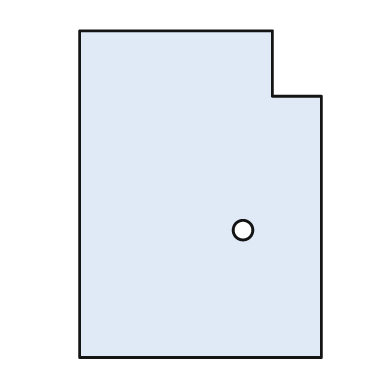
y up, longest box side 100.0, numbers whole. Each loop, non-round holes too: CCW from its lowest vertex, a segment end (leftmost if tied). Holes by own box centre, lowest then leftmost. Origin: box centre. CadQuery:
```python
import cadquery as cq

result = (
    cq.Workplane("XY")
    .moveTo(-37.0, -50.0)
    .lineTo(37.0, -50.0)
    .lineTo(37.0, 30.0)
    .lineTo(22.0, 30.0)
    .lineTo(22.0, 50.0)
    .lineTo(-37.0, 50.0)
    .close()
    .moveTo(13.0, -11.0)
    .circle(3.0)
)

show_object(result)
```